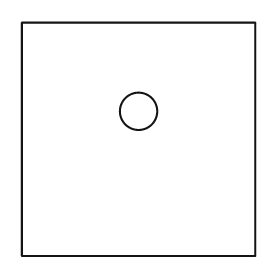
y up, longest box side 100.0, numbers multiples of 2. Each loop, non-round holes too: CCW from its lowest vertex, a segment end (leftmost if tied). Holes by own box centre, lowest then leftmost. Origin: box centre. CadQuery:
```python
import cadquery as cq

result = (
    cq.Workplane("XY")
    .moveTo(-50.0, -50.0)
    .lineTo(50.0, -50.0)
    .lineTo(50.0, 50.0)
    .lineTo(-50.0, 50.0)
    .close()
    .moveTo(0.0, 12.0)
    .circle(8.0)
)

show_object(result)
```